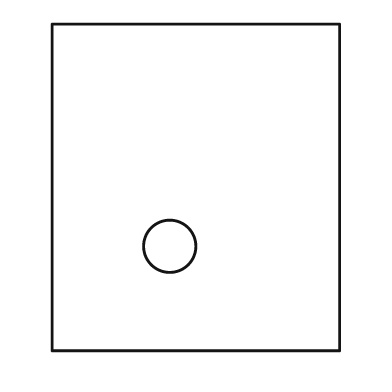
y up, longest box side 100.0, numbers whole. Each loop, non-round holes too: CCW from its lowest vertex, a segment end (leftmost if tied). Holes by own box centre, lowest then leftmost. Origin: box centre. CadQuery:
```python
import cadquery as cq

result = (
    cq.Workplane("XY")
    .moveTo(-44.0, -50.0)
    .lineTo(44.0, -50.0)
    .lineTo(44.0, 50.0)
    .lineTo(-44.0, 50.0)
    .close()
    .moveTo(-8.0, -18.0)
    .circle(8.0)
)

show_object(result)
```